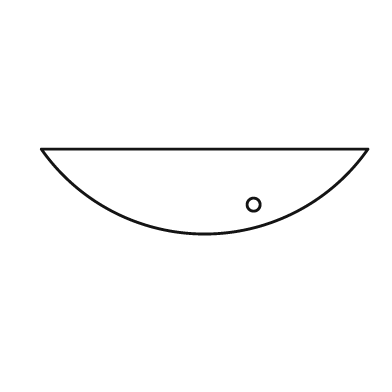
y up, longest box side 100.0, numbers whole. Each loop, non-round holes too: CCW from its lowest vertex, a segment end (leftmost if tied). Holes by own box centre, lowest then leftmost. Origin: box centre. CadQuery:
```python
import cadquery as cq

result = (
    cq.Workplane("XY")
    .moveTo(-50.0, 13.0)
    .threePointArc((0.0, -13.0), (50.0, 13.0))
    .close()
    .moveTo(15.0, -4.0)
    .circle(2.0)
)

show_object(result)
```